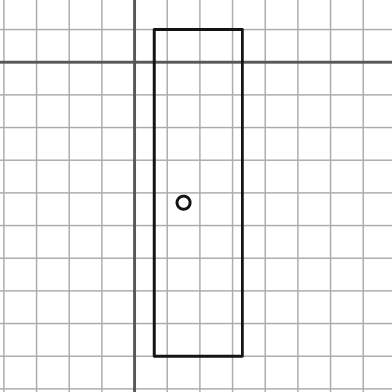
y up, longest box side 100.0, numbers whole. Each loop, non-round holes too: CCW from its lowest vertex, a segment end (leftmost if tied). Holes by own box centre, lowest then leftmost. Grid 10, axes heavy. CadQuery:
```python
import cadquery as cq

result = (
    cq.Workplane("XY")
    .moveTo(6.0, -90.0)
    .lineTo(33.0, -90.0)
    .lineTo(33.0, 10.0)
    .lineTo(6.0, 10.0)
    .close()
    .moveTo(15.0, -43.0)
    .circle(2.0)
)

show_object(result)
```